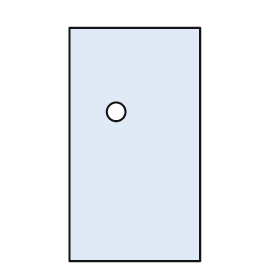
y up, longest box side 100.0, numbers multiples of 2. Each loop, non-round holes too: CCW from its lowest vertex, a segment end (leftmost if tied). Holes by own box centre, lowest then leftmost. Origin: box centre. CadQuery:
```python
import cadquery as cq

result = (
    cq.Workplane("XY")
    .moveTo(-28.0, -50.0)
    .lineTo(28.0, -50.0)
    .lineTo(28.0, 50.0)
    .lineTo(-28.0, 50.0)
    .close()
    .moveTo(-8.0, 14.0)
    .circle(4.0)
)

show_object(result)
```